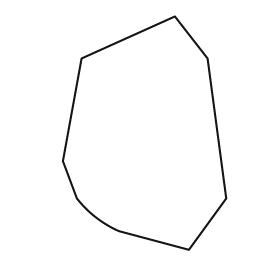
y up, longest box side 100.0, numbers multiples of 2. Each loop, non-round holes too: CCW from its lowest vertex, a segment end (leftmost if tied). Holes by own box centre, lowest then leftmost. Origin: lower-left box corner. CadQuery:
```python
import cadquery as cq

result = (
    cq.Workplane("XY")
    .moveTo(54.0, 0.0)
    .lineTo(70.0, 22.0)
    .lineTo(62.0, 82.0)
    .lineTo(48.0, 100.0)
    .lineTo(8.0, 82.0)
    .lineTo(0.0, 38.0)
    .lineTo(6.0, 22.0)
    .threePointArc((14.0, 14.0), (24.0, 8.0))
    .close()
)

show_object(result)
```